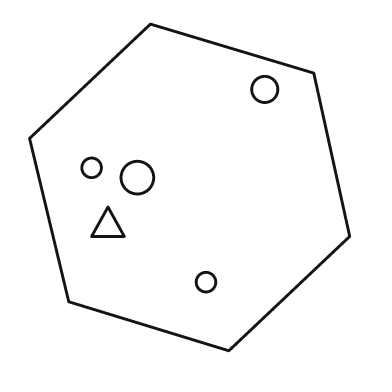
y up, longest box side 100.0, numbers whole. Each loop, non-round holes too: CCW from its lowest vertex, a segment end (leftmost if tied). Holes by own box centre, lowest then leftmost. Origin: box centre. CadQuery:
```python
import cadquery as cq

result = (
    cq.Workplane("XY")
    .moveTo(12.0, -50.0)
    .lineTo(49.0, -15.0)
    .lineTo(38.0, 35.0)
    .lineTo(-12.0, 50.0)
    .lineTo(-49.0, 15.0)
    .lineTo(-37.0, -35.0)
    .close()
    .moveTo(5.0, -29.0)
    .circle(3.0)
    .moveTo(-30.0, -15.0)
    .lineTo(-20.0, -15.0)
    .lineTo(-25.0, -6.0)
    .close()
    .moveTo(-16.0, 3.0)
    .circle(5.0)
    .moveTo(-30.0, 6.0)
    .circle(3.0)
    .moveTo(23.0, 30.0)
    .circle(4.0)
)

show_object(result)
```